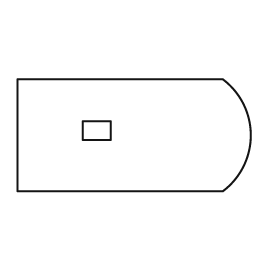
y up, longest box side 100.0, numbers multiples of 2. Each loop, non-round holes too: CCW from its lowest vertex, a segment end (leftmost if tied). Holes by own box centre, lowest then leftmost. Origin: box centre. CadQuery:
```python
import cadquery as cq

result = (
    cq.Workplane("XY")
    .moveTo(-50.0, -24.0)
    .lineTo(38.0, -24.0)
    .threePointArc((50.0, 0.0), (38.0, 24.0))
    .lineTo(-50.0, 24.0)
    .close()
    .moveTo(-22.0, -2.0)
    .lineTo(-10.0, -2.0)
    .lineTo(-10.0, 6.0)
    .lineTo(-22.0, 6.0)
    .close()
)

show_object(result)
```